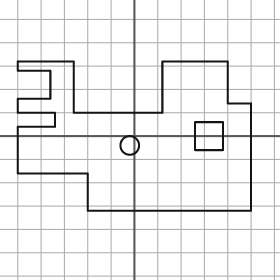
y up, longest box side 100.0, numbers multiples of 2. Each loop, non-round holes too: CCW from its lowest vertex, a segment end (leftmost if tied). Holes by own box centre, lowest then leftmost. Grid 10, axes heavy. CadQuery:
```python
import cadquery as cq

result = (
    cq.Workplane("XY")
    .moveTo(-20.0, -32.0)
    .lineTo(50.0, -32.0)
    .lineTo(50.0, 14.0)
    .lineTo(40.0, 14.0)
    .lineTo(40.0, 32.0)
    .lineTo(12.0, 32.0)
    .lineTo(12.0, 10.0)
    .lineTo(-26.0, 10.0)
    .lineTo(-26.0, 32.0)
    .lineTo(-50.0, 32.0)
    .lineTo(-50.0, 28.0)
    .lineTo(-36.0, 28.0)
    .lineTo(-36.0, 16.0)
    .lineTo(-50.0, 16.0)
    .lineTo(-50.0, 10.0)
    .lineTo(-34.0, 10.0)
    .lineTo(-34.0, 4.0)
    .lineTo(-50.0, 4.0)
    .lineTo(-50.0, -16.0)
    .lineTo(-20.0, -16.0)
    .close()
    .moveTo(-2.0, -4.0)
    .circle(4.0)
    .moveTo(26.0, -6.0)
    .lineTo(38.0, -6.0)
    .lineTo(38.0, 6.0)
    .lineTo(26.0, 6.0)
    .close()
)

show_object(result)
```